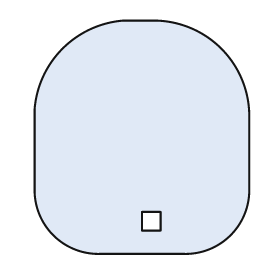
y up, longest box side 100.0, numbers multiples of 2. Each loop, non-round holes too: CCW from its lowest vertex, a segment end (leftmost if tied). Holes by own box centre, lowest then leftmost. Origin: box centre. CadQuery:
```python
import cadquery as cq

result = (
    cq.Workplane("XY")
    .moveTo(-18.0, -50.0)
    .lineTo(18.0, -50.0)
    .threePointArc((38.0, -42.0), (46.0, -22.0))
    .lineTo(46.0, 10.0)
    .threePointArc((34.0, 38.0), (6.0, 50.0))
    .lineTo(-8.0, 50.0)
    .threePointArc((-34.0, 38.0), (-46.0, 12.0))
    .lineTo(-46.0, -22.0)
    .threePointArc((-38.0, -42.0), (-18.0, -50.0))
    .close()
    .moveTo(0.0, -40.0)
    .lineTo(8.0, -40.0)
    .lineTo(8.0, -32.0)
    .lineTo(0.0, -32.0)
    .close()
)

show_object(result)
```